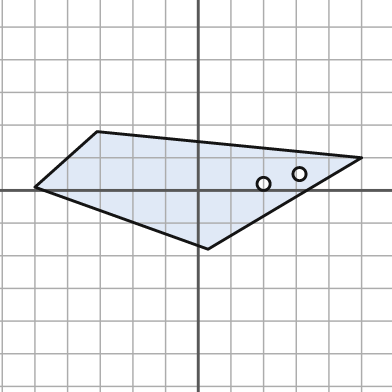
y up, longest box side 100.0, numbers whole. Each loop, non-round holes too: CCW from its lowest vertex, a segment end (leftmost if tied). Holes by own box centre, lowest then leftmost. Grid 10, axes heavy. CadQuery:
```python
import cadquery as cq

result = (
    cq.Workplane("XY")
    .moveTo(3.0, -18.0)
    .lineTo(50.0, 10.0)
    .lineTo(-31.0, 18.0)
    .lineTo(-50.0, 1.0)
    .close()
    .moveTo(20.0, 2.0)
    .circle(2.0)
    .moveTo(31.0, 5.0)
    .circle(2.0)
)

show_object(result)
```